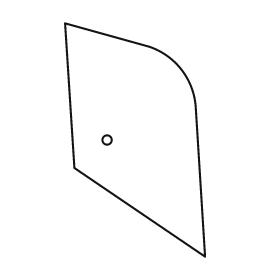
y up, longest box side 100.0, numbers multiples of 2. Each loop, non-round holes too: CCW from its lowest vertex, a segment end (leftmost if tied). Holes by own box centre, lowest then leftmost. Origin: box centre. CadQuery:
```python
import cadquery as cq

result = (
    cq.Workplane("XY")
    .moveTo(30.0, -50.0)
    .lineTo(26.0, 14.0)
    .threePointArc((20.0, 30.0), (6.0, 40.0))
    .lineTo(-30.0, 50.0)
    .lineTo(-26.0, -12.0)
    .close()
    .moveTo(-12.0, 0.0)
    .circle(2.0)
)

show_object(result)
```